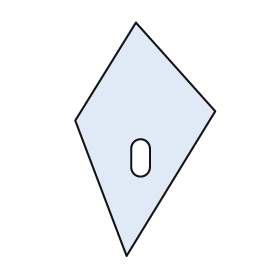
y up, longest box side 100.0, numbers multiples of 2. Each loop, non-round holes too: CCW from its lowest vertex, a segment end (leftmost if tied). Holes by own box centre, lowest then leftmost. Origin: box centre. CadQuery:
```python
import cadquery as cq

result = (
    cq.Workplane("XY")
    .moveTo(-8.0, -50.0)
    .lineTo(30.0, 12.0)
    .lineTo(-4.0, 50.0)
    .lineTo(-30.0, 8.0)
    .close()
    .moveTo(-6.0, -12.0)
    .threePointArc((-2.0, -16.0), (2.0, -12.0))
    .lineTo(2.0, -4.0)
    .threePointArc((-2.0, 0.0), (-6.0, -4.0))
    .close()
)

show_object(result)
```